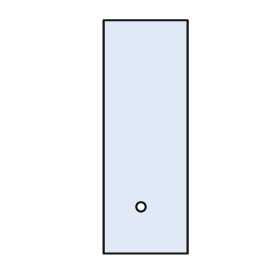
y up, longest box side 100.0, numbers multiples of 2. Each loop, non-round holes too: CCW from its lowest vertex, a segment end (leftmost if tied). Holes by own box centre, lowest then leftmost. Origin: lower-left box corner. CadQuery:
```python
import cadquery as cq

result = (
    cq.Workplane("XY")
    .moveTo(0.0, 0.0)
    .lineTo(36.0, 0.0)
    .lineTo(36.0, 100.0)
    .lineTo(0.0, 100.0)
    .close()
    .moveTo(16.0, 20.0)
    .circle(2.0)
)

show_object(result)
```